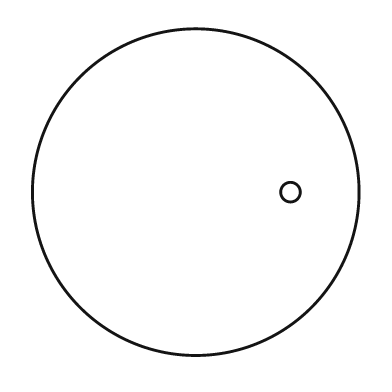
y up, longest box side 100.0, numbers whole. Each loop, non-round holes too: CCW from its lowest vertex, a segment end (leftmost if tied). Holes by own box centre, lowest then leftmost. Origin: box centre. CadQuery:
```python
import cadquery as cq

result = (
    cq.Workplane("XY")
    .moveTo(0.0, 0.0)
    .circle(50.0)
    .moveTo(29.0, 0.0)
    .circle(3.0)
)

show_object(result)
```